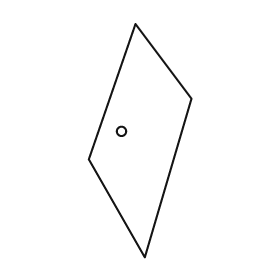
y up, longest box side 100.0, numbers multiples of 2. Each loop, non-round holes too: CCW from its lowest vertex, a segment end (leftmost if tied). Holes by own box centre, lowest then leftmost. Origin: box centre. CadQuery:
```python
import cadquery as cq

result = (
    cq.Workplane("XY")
    .moveTo(2.0, -50.0)
    .lineTo(22.0, 18.0)
    .lineTo(-2.0, 50.0)
    .lineTo(-22.0, -8.0)
    .close()
    .moveTo(-8.0, 4.0)
    .circle(2.0)
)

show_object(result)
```